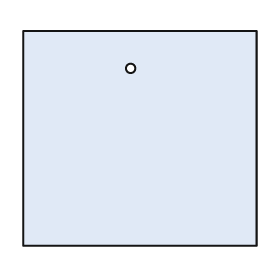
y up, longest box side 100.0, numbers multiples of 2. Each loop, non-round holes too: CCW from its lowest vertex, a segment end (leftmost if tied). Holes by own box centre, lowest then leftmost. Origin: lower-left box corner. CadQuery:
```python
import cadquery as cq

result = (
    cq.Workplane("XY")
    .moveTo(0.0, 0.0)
    .lineTo(100.0, 0.0)
    .lineTo(100.0, 92.0)
    .lineTo(0.0, 92.0)
    .close()
    .moveTo(46.0, 76.0)
    .circle(2.0)
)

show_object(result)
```